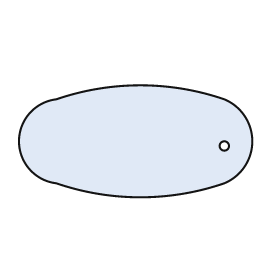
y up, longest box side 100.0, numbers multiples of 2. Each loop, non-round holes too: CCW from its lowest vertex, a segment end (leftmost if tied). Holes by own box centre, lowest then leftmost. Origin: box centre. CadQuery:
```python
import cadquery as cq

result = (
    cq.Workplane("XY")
    .moveTo(-34.0, -18.0)
    .threePointArc((2.0, -24.0), (38.0, -18.0))
    .threePointArc((50.0, 0.0), (38.0, 18.0))
    .threePointArc((2.0, 24.0), (-34.0, 18.0))
    .threePointArc((-50.0, 0.0), (-34.0, -18.0))
    .close()
    .moveTo(38.0, -2.0)
    .circle(2.0)
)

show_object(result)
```